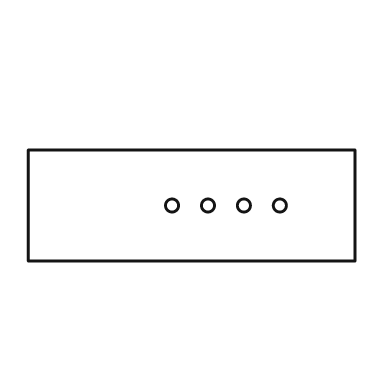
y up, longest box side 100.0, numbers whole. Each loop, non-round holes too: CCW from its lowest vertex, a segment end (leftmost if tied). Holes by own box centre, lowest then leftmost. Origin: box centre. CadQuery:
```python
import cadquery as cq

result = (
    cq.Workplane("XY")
    .moveTo(-50.0, -17.0)
    .lineTo(50.0, -17.0)
    .lineTo(50.0, 17.0)
    .lineTo(-50.0, 17.0)
    .close()
    .moveTo(-6.0, 0.0)
    .circle(2.0)
    .moveTo(5.0, 0.0)
    .circle(2.0)
    .moveTo(16.0, 0.0)
    .circle(2.0)
    .moveTo(27.0, 0.0)
    .circle(2.0)
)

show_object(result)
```